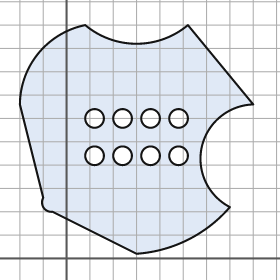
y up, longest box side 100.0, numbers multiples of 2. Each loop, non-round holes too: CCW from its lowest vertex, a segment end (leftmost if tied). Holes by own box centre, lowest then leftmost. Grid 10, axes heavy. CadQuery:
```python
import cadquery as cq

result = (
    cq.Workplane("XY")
    .moveTo(30.0, 2.0)
    .threePointArc((52.0, 8.0), (70.0, 22.0))
    .threePointArc((58.0, 48.0), (80.0, 66.0))
    .lineTo(52.0, 100.0)
    .threePointArc((30.0, 92.0), (8.0, 100.0))
    .threePointArc((-12.0, 88.0), (-20.0, 66.0))
    .lineTo(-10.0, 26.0)
    .threePointArc((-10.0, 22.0), (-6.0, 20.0))
    .close()
    .moveTo(12.0, 44.0)
    .circle(4.0)
    .moveTo(24.0, 44.0)
    .circle(4.0)
    .moveTo(36.0, 44.0)
    .circle(4.0)
    .moveTo(48.0, 44.0)
    .circle(4.0)
    .moveTo(12.0, 60.0)
    .circle(4.0)
    .moveTo(24.0, 60.0)
    .circle(4.0)
    .moveTo(36.0, 60.0)
    .circle(4.0)
    .moveTo(48.0, 60.0)
    .circle(4.0)
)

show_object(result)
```